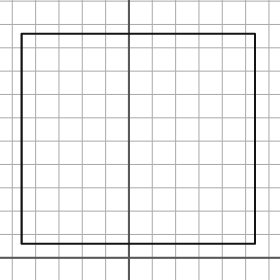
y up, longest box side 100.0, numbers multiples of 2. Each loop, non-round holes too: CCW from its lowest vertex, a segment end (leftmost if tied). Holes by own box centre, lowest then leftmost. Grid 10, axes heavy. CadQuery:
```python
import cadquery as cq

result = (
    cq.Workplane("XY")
    .moveTo(-46.0, 6.0)
    .lineTo(54.0, 6.0)
    .lineTo(54.0, 96.0)
    .lineTo(-46.0, 96.0)
    .close()
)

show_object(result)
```